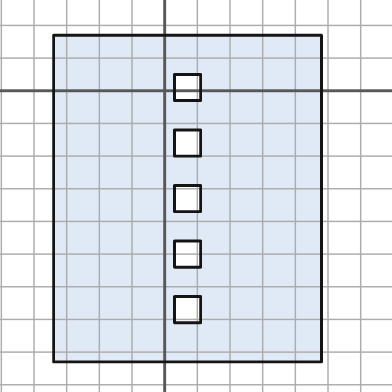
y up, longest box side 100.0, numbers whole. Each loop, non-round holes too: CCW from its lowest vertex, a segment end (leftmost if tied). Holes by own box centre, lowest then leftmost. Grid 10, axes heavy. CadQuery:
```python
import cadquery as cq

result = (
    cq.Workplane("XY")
    .moveTo(-34.0, -83.0)
    .lineTo(48.0, -83.0)
    .lineTo(48.0, 17.0)
    .lineTo(-34.0, 17.0)
    .close()
    .moveTo(3.0, -71.0)
    .lineTo(11.0, -71.0)
    .lineTo(11.0, -63.0)
    .lineTo(3.0, -63.0)
    .close()
    .moveTo(3.0, -54.0)
    .lineTo(11.0, -54.0)
    .lineTo(11.0, -46.0)
    .lineTo(3.0, -46.0)
    .close()
    .moveTo(3.0, -37.0)
    .lineTo(11.0, -37.0)
    .lineTo(11.0, -29.0)
    .lineTo(3.0, -29.0)
    .close()
    .moveTo(3.0, -20.0)
    .lineTo(11.0, -20.0)
    .lineTo(11.0, -12.0)
    .lineTo(3.0, -12.0)
    .close()
    .moveTo(3.0, -3.0)
    .lineTo(11.0, -3.0)
    .lineTo(11.0, 5.0)
    .lineTo(3.0, 5.0)
    .close()
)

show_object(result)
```